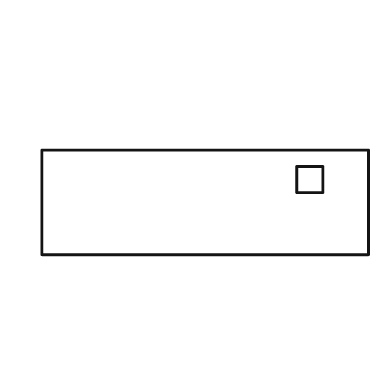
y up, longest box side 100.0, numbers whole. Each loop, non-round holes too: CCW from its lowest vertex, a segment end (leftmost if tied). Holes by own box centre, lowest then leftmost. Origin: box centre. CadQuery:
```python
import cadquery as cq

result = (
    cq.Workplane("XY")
    .moveTo(-50.0, -16.0)
    .lineTo(50.0, -16.0)
    .lineTo(50.0, 16.0)
    .lineTo(-50.0, 16.0)
    .close()
    .moveTo(28.0, 3.0)
    .lineTo(36.0, 3.0)
    .lineTo(36.0, 11.0)
    .lineTo(28.0, 11.0)
    .close()
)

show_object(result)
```